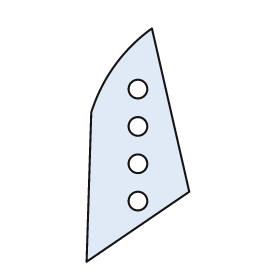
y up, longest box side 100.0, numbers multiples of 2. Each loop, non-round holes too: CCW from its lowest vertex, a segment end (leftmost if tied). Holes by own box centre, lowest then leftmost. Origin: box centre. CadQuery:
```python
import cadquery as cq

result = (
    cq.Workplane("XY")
    .moveTo(-22.0, -50.0)
    .lineTo(22.0, -20.0)
    .lineTo(6.0, 50.0)
    .threePointArc((-10.0, 34.0), (-20.0, 14.0))
    .close()
    .moveTo(0.0, -24.0)
    .circle(4.0)
    .moveTo(0.0, -8.0)
    .circle(4.0)
    .moveTo(0.0, 8.0)
    .circle(4.0)
    .moveTo(0.0, 24.0)
    .circle(4.0)
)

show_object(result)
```